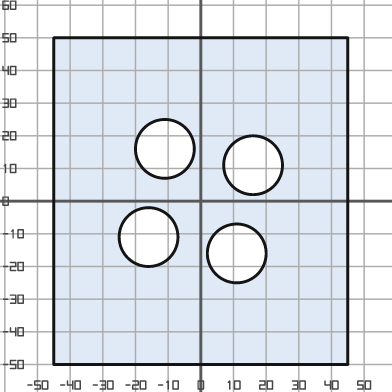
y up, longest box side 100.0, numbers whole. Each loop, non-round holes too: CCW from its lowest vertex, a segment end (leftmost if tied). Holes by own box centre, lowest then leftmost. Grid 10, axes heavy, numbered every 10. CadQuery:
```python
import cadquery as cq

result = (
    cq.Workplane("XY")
    .moveTo(-45.0, -50.0)
    .lineTo(45.0, -50.0)
    .lineTo(45.0, 50.0)
    .lineTo(-45.0, 50.0)
    .close()
    .moveTo(11.0, -16.0)
    .circle(9.0)
    .moveTo(-16.0, -11.0)
    .circle(9.0)
    .moveTo(16.0, 11.0)
    .circle(9.0)
    .moveTo(-11.0, 16.0)
    .circle(9.0)
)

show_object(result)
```